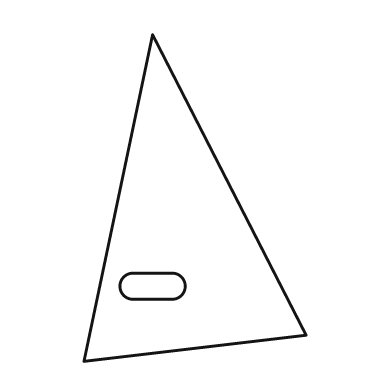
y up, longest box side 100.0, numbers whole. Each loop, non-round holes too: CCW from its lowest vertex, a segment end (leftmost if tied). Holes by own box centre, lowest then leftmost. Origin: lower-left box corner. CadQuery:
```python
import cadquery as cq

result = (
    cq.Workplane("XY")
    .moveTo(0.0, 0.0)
    .lineTo(68.0, 8.0)
    .lineTo(21.0, 100.0)
    .close()
    .moveTo(15.0, 19.0)
    .lineTo(27.0, 19.0)
    .threePointArc((31.0, 23.0), (27.0, 27.0))
    .lineTo(15.0, 27.0)
    .threePointArc((11.0, 23.0), (15.0, 19.0))
    .close()
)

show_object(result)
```